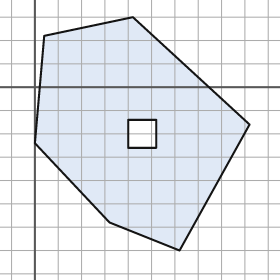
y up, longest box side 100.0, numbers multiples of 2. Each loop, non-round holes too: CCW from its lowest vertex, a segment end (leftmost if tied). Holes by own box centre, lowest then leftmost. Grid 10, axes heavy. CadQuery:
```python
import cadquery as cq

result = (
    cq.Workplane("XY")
    .moveTo(62.0, -70.0)
    .lineTo(92.0, -16.0)
    .lineTo(42.0, 30.0)
    .lineTo(4.0, 22.0)
    .lineTo(0.0, -24.0)
    .lineTo(32.0, -58.0)
    .close()
    .moveTo(40.0, -26.0)
    .lineTo(52.0, -26.0)
    .lineTo(52.0, -14.0)
    .lineTo(40.0, -14.0)
    .close()
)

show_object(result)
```